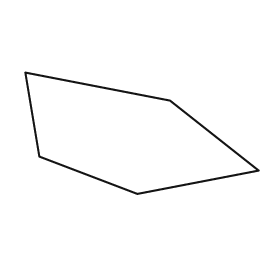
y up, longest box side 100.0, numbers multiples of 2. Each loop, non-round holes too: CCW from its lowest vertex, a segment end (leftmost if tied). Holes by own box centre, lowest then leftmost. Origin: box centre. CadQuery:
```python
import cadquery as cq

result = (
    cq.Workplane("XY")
    .moveTo(-2.0, -26.0)
    .lineTo(50.0, -16.0)
    .lineTo(12.0, 14.0)
    .lineTo(-50.0, 26.0)
    .lineTo(-44.0, -10.0)
    .close()
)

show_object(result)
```